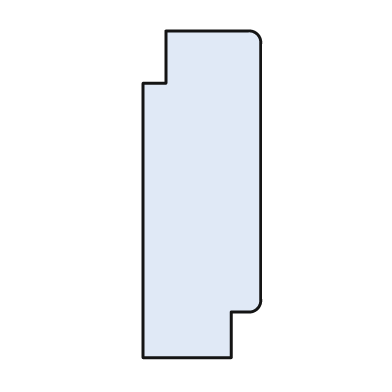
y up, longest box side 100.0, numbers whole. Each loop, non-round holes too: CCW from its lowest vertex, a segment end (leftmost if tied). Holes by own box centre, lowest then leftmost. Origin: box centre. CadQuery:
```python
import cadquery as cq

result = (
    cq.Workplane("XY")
    .moveTo(-18.0, -50.0)
    .lineTo(9.0, -50.0)
    .lineTo(9.0, -36.0)
    .lineTo(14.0, -36.0)
    .threePointArc((17.0, -35.0), (18.0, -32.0))
    .lineTo(18.0, 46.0)
    .threePointArc((17.0, 49.0), (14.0, 50.0))
    .lineTo(-11.0, 50.0)
    .lineTo(-11.0, 34.0)
    .lineTo(-18.0, 34.0)
    .close()
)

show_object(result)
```